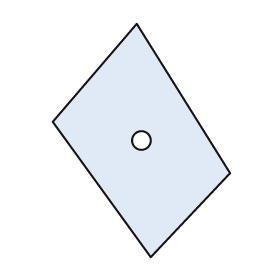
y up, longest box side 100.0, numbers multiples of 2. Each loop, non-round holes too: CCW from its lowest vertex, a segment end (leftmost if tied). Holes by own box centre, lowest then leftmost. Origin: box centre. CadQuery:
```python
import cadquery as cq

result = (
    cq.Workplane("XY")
    .moveTo(4.0, -50.0)
    .lineTo(38.0, -14.0)
    .lineTo(-2.0, 50.0)
    .lineTo(-38.0, 8.0)
    .close()
    .moveTo(0.0, 0.0)
    .circle(4.0)
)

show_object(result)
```